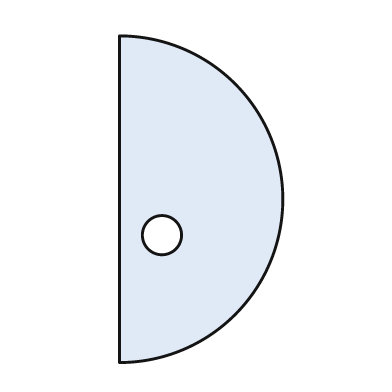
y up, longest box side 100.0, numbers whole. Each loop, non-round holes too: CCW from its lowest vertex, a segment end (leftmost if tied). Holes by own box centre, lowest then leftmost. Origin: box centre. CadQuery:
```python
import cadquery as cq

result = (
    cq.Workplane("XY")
    .moveTo(-25.0, -50.0)
    .threePointArc((25.0, 0.0), (-25.0, 50.0))
    .close()
    .moveTo(-12.0, -11.0)
    .circle(6.0)
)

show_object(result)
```